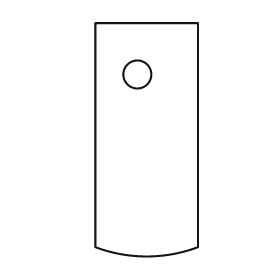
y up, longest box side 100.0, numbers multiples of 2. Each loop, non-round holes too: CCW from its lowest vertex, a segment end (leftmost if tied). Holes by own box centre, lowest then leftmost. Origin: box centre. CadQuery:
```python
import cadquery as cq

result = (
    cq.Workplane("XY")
    .moveTo(-22.0, -46.0)
    .threePointArc((0.0, -50.0), (22.0, -46.0))
    .lineTo(22.0, 50.0)
    .lineTo(-22.0, 50.0)
    .close()
    .moveTo(-4.0, 28.0)
    .circle(6.0)
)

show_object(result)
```